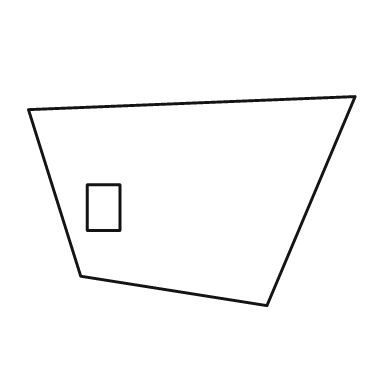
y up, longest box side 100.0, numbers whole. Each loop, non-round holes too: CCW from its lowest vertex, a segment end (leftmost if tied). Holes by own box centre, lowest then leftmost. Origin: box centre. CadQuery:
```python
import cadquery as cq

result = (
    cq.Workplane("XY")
    .moveTo(23.0, -32.0)
    .lineTo(50.0, 32.0)
    .lineTo(-50.0, 28.0)
    .lineTo(-34.0, -23.0)
    .close()
    .moveTo(-32.0, -9.0)
    .lineTo(-22.0, -9.0)
    .lineTo(-22.0, 5.0)
    .lineTo(-32.0, 5.0)
    .close()
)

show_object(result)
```